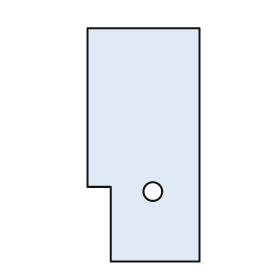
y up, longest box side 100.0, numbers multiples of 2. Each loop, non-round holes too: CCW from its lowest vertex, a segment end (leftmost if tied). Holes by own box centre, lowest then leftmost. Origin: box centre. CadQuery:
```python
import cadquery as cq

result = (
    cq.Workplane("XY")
    .moveTo(-14.0, -50.0)
    .lineTo(24.0, -50.0)
    .lineTo(24.0, 50.0)
    .lineTo(-24.0, 50.0)
    .lineTo(-24.0, -18.0)
    .lineTo(-14.0, -18.0)
    .close()
    .moveTo(4.0, -20.0)
    .circle(4.0)
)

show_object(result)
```